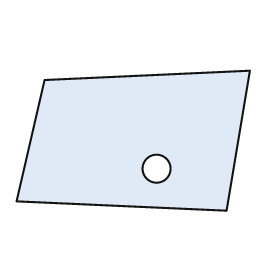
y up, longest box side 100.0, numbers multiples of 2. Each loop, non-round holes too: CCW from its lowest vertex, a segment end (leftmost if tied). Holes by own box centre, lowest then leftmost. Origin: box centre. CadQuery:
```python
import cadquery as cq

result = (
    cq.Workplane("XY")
    .moveTo(40.0, -30.0)
    .lineTo(50.0, 30.0)
    .lineTo(-38.0, 26.0)
    .lineTo(-50.0, -26.0)
    .close()
    .moveTo(10.0, -12.0)
    .circle(6.0)
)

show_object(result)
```